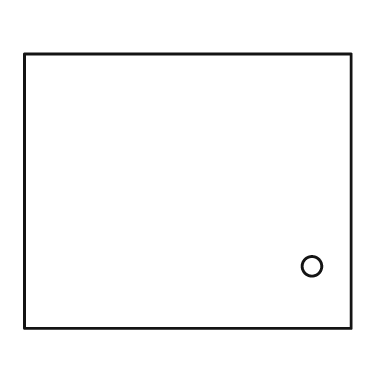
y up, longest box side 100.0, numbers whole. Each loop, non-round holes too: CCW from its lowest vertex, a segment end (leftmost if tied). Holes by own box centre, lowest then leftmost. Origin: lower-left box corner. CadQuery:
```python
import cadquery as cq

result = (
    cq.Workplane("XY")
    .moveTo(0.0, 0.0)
    .lineTo(100.0, 0.0)
    .lineTo(100.0, 84.0)
    .lineTo(0.0, 84.0)
    .close()
    .moveTo(88.0, 19.0)
    .circle(3.0)
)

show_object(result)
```